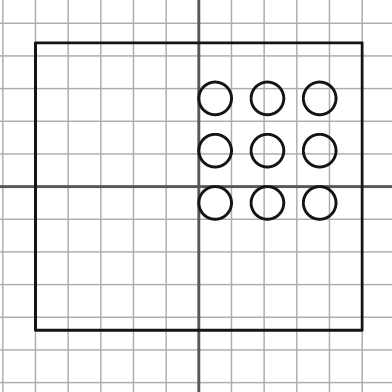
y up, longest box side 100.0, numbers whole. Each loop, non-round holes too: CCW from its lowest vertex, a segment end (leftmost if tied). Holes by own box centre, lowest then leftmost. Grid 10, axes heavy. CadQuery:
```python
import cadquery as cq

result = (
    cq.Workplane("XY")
    .moveTo(-50.0, -44.0)
    .lineTo(50.0, -44.0)
    .lineTo(50.0, 44.0)
    .lineTo(-50.0, 44.0)
    .close()
    .moveTo(5.0, -5.0)
    .circle(5.0)
    .moveTo(21.0, -5.0)
    .circle(5.0)
    .moveTo(37.0, -5.0)
    .circle(5.0)
    .moveTo(5.0, 11.0)
    .circle(5.0)
    .moveTo(21.0, 11.0)
    .circle(5.0)
    .moveTo(37.0, 11.0)
    .circle(5.0)
    .moveTo(5.0, 27.0)
    .circle(5.0)
    .moveTo(21.0, 27.0)
    .circle(5.0)
    .moveTo(37.0, 27.0)
    .circle(5.0)
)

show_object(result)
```